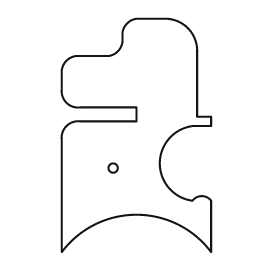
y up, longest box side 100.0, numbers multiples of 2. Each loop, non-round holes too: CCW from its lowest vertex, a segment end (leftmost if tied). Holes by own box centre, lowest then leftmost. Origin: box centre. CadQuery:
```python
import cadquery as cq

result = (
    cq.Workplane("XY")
    .moveTo(-32.0, -50.0)
    .threePointArc((0.0, -34.0), (32.0, -50.0))
    .lineTo(32.0, -28.0)
    .threePointArc((28.0, -26.0), (24.0, -28.0))
    .threePointArc((10.0, -12.0), (24.0, 4.0))
    .lineTo(32.0, 4.0)
    .lineTo(32.0, 8.0)
    .lineTo(26.0, 8.0)
    .lineTo(26.0, 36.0)
    .threePointArc((22.0, 46.0), (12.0, 50.0))
    .lineTo(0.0, 50.0)
    .threePointArc((-4.0, 48.0), (-6.0, 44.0))
    .lineTo(-6.0, 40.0)
    .threePointArc((-8.0, 36.0), (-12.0, 34.0))
    .lineTo(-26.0, 34.0)
    .threePointArc((-30.0, 32.0), (-32.0, 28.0))
    .lineTo(-32.0, 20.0)
    .threePointArc((-30.0, 14.0), (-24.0, 12.0))
    .lineTo(0.0, 12.0)
    .lineTo(0.0, 6.0)
    .lineTo(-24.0, 6.0)
    .threePointArc((-30.0, 4.0), (-32.0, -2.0))
    .close()
    .moveTo(-10.0, -14.0)
    .circle(2.0)
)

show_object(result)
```